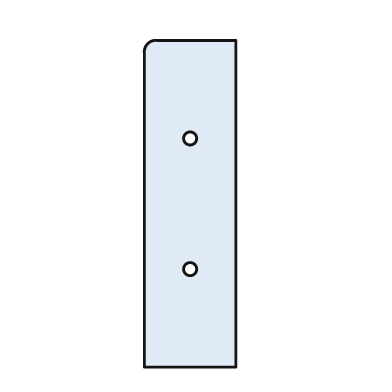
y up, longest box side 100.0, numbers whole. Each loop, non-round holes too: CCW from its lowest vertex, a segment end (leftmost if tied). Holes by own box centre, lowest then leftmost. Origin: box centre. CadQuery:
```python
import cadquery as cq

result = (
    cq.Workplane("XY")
    .moveTo(-14.0, -50.0)
    .lineTo(14.0, -50.0)
    .lineTo(14.0, 50.0)
    .lineTo(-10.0, 50.0)
    .threePointArc((-13.0, 49.0), (-14.0, 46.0))
    .close()
    .moveTo(0.0, -20.0)
    .circle(2.0)
    .moveTo(0.0, 20.0)
    .circle(2.0)
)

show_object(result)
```